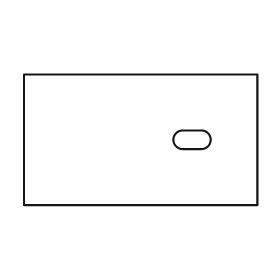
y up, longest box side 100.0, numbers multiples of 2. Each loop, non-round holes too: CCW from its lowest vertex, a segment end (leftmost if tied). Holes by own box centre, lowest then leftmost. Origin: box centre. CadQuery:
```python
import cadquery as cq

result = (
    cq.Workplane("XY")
    .moveTo(-50.0, -28.0)
    .lineTo(50.0, -28.0)
    .lineTo(50.0, 28.0)
    .lineTo(-50.0, 28.0)
    .close()
    .moveTo(18.0, -4.0)
    .lineTo(26.0, -4.0)
    .threePointArc((30.0, 0.0), (26.0, 4.0))
    .lineTo(18.0, 4.0)
    .threePointArc((14.0, 0.0), (18.0, -4.0))
    .close()
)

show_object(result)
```